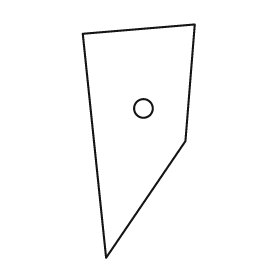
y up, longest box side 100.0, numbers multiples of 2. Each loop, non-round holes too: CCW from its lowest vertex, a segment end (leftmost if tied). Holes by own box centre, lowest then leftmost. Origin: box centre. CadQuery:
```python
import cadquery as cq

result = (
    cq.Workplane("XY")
    .moveTo(-14.0, -50.0)
    .lineTo(20.0, 0.0)
    .lineTo(24.0, 50.0)
    .lineTo(-24.0, 46.0)
    .close()
    .moveTo(2.0, 14.0)
    .circle(4.0)
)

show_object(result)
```